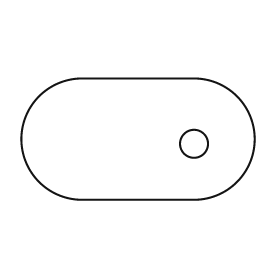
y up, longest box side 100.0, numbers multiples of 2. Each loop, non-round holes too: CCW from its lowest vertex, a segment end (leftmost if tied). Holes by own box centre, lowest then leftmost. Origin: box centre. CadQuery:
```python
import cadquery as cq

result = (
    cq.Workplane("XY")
    .moveTo(-24.0, -26.0)
    .lineTo(24.0, -26.0)
    .threePointArc((50.0, 0.0), (24.0, 26.0))
    .lineTo(-24.0, 26.0)
    .threePointArc((-50.0, 0.0), (-24.0, -26.0))
    .close()
    .moveTo(24.0, -2.0)
    .circle(6.0)
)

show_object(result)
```